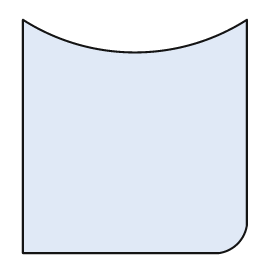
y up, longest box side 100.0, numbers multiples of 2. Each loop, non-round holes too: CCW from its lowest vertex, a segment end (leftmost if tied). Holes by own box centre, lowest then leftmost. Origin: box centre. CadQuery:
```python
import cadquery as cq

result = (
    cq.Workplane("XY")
    .moveTo(-48.0, -50.0)
    .lineTo(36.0, -50.0)
    .threePointArc((44.0, -46.0), (48.0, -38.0))
    .lineTo(48.0, 50.0)
    .threePointArc((0.0, 36.0), (-48.0, 50.0))
    .close()
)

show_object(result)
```